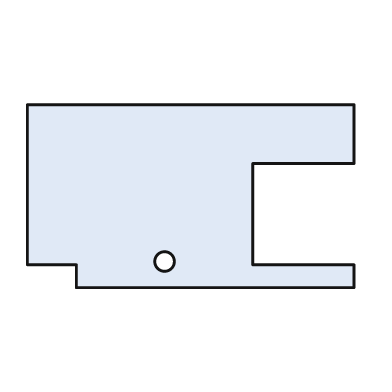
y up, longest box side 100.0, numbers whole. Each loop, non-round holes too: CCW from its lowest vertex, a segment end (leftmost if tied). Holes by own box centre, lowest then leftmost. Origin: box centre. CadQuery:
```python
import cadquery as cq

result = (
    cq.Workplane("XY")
    .moveTo(-35.0, -28.0)
    .lineTo(50.0, -28.0)
    .lineTo(50.0, -21.0)
    .lineTo(19.0, -21.0)
    .lineTo(19.0, 10.0)
    .lineTo(50.0, 10.0)
    .lineTo(50.0, 28.0)
    .lineTo(-50.0, 28.0)
    .lineTo(-50.0, -21.0)
    .lineTo(-35.0, -21.0)
    .close()
    .moveTo(-8.0, -20.0)
    .circle(3.0)
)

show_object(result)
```